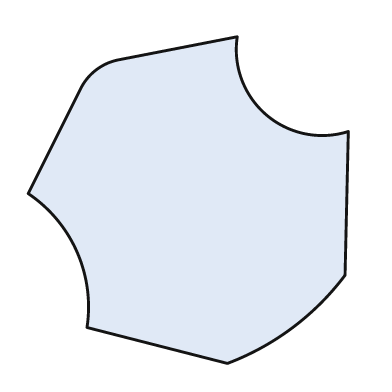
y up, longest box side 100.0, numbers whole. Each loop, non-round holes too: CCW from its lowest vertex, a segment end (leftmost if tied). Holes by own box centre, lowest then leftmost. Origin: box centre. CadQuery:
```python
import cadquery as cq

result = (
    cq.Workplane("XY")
    .moveTo(12.0, -50.0)
    .threePointArc((32.0, -39.0), (48.0, -23.0))
    .lineTo(49.0, 21.0)
    .threePointArc((24.0, 26.0), (15.0, 50.0))
    .lineTo(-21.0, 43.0)
    .threePointArc((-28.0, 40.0), (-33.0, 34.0))
    .lineTo(-49.0, 2.0)
    .threePointArc((-34.0, -16.0), (-31.0, -39.0))
    .close()
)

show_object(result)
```